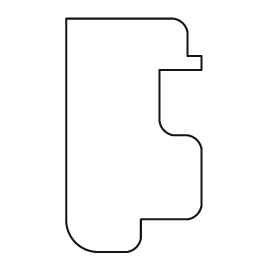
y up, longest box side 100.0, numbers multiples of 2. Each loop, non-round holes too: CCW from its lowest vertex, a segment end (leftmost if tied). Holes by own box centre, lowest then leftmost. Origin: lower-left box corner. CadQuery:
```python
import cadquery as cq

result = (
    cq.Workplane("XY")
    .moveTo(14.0, 0.0)
    .lineTo(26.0, 0.0)
    .threePointArc((30.0, 2.0), (32.0, 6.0))
    .lineTo(32.0, 14.0)
    .lineTo(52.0, 14.0)
    .threePointArc((56.0, 16.0), (58.0, 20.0))
    .lineTo(58.0, 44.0)
    .threePointArc((56.0, 48.0), (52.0, 50.0))
    .lineTo(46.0, 50.0)
    .threePointArc((42.0, 52.0), (40.0, 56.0))
    .lineTo(40.0, 78.0)
    .lineTo(58.0, 78.0)
    .lineTo(58.0, 84.0)
    .lineTo(52.0, 84.0)
    .lineTo(52.0, 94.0)
    .threePointArc((50.0, 98.0), (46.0, 100.0))
    .lineTo(0.0, 100.0)
    .lineTo(0.0, 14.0)
    .threePointArc((4.0, 4.0), (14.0, 0.0))
    .close()
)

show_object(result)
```